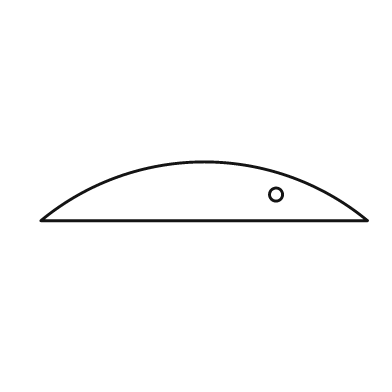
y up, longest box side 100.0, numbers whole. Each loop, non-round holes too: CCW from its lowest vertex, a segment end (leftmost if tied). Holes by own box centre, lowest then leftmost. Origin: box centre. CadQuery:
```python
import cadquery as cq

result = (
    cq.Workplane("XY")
    .moveTo(-50.0, -9.0)
    .lineTo(50.0, -9.0)
    .threePointArc((0.0, 9.0), (-50.0, -9.0))
    .close()
    .moveTo(22.0, -1.0)
    .circle(2.0)
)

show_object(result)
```